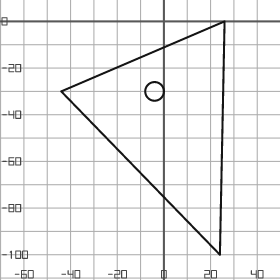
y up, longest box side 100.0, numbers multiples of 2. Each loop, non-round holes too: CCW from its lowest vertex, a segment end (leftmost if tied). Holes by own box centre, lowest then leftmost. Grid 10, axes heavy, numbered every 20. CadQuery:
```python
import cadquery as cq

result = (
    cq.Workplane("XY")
    .moveTo(24.0, -100.0)
    .lineTo(26.0, 0.0)
    .lineTo(-44.0, -30.0)
    .close()
    .moveTo(-4.0, -30.0)
    .circle(4.0)
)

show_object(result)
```